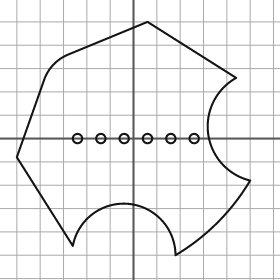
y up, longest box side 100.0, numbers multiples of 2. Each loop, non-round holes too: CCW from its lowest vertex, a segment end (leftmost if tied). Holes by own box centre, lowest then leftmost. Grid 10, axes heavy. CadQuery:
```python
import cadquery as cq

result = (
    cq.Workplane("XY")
    .moveTo(18.0, -50.0)
    .threePointArc((36.0, -36.0), (50.0, -18.0))
    .threePointArc((32.0, 2.0), (44.0, 26.0))
    .lineTo(6.0, 50.0)
    .lineTo(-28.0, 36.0)
    .threePointArc((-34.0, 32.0), (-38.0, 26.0))
    .lineTo(-50.0, -8.0)
    .lineTo(-26.0, -46.0)
    .threePointArc((-2.0, -28.0), (18.0, -50.0))
    .close()
    .moveTo(-24.0, 0.0)
    .circle(2.0)
    .moveTo(-14.0, 0.0)
    .circle(2.0)
    .moveTo(-4.0, 0.0)
    .circle(2.0)
    .moveTo(6.0, 0.0)
    .circle(2.0)
    .moveTo(16.0, 0.0)
    .circle(2.0)
    .moveTo(26.0, 0.0)
    .circle(2.0)
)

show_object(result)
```